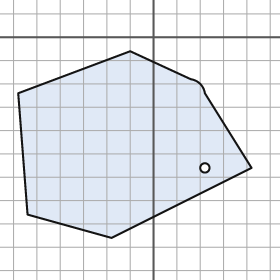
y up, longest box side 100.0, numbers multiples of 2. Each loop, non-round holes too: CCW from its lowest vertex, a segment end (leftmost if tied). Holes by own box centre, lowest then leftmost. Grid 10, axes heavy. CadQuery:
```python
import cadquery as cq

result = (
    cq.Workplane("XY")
    .moveTo(-18.0, -86.0)
    .lineTo(42.0, -56.0)
    .lineTo(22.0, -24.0)
    .threePointArc((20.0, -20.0), (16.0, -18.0))
    .lineTo(-10.0, -6.0)
    .lineTo(-58.0, -24.0)
    .lineTo(-54.0, -76.0)
    .close()
    .moveTo(22.0, -56.0)
    .circle(2.0)
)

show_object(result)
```